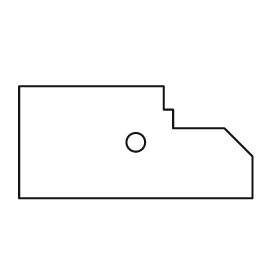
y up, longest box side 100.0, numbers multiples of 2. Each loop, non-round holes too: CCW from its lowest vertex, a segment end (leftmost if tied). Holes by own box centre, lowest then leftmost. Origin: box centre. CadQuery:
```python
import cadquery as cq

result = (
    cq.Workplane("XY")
    .moveTo(-50.0, -24.0)
    .lineTo(50.0, -24.0)
    .lineTo(50.0, -6.0)
    .lineTo(38.0, 6.0)
    .lineTo(16.0, 6.0)
    .lineTo(16.0, 14.0)
    .lineTo(12.0, 14.0)
    .lineTo(12.0, 24.0)
    .lineTo(-50.0, 24.0)
    .close()
    .moveTo(0.0, 0.0)
    .circle(4.0)
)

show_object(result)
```